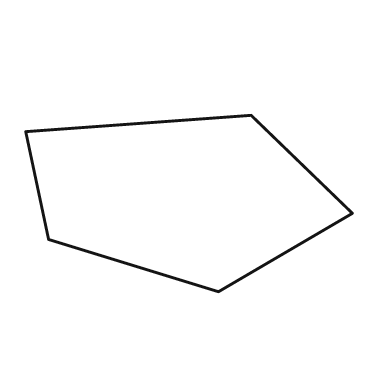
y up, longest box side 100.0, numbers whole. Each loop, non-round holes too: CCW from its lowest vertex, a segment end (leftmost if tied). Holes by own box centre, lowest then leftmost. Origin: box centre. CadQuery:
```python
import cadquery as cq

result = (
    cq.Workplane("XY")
    .moveTo(9.0, -27.0)
    .lineTo(50.0, -3.0)
    .lineTo(19.0, 27.0)
    .lineTo(-50.0, 22.0)
    .lineTo(-43.0, -11.0)
    .close()
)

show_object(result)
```